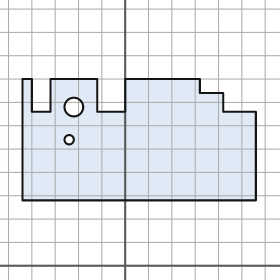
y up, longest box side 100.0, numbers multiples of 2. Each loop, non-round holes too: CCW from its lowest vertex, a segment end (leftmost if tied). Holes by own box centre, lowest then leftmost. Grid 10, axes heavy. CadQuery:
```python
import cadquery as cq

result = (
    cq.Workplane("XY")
    .moveTo(-44.0, 28.0)
    .lineTo(56.0, 28.0)
    .lineTo(56.0, 66.0)
    .lineTo(42.0, 66.0)
    .lineTo(42.0, 74.0)
    .lineTo(32.0, 74.0)
    .lineTo(32.0, 80.0)
    .lineTo(0.0, 80.0)
    .lineTo(0.0, 66.0)
    .lineTo(-12.0, 66.0)
    .lineTo(-12.0, 80.0)
    .lineTo(-32.0, 80.0)
    .lineTo(-32.0, 66.0)
    .lineTo(-40.0, 66.0)
    .lineTo(-40.0, 80.0)
    .lineTo(-44.0, 80.0)
    .close()
    .moveTo(-24.0, 54.0)
    .circle(2.0)
    .moveTo(-22.0, 68.0)
    .circle(4.0)
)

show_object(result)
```